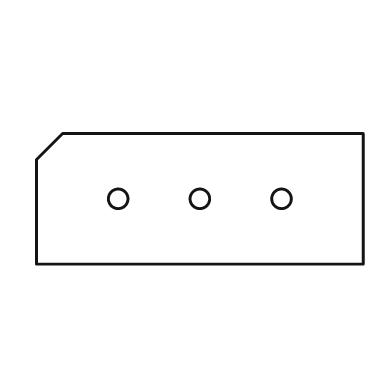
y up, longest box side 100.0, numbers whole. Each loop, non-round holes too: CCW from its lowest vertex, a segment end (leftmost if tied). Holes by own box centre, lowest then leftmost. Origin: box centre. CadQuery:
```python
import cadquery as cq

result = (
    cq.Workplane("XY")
    .moveTo(-50.0, -20.0)
    .lineTo(50.0, -20.0)
    .lineTo(50.0, 20.0)
    .lineTo(-42.0, 20.0)
    .lineTo(-50.0, 12.0)
    .close()
    .moveTo(-25.0, 0.0)
    .circle(3.0)
    .moveTo(0.0, 0.0)
    .circle(3.0)
    .moveTo(25.0, 0.0)
    .circle(3.0)
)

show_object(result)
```